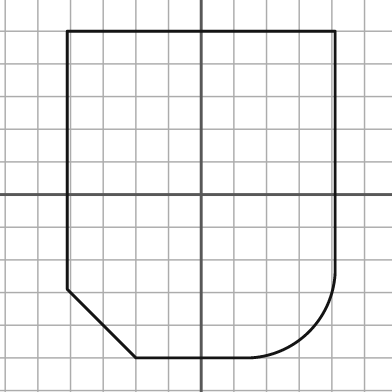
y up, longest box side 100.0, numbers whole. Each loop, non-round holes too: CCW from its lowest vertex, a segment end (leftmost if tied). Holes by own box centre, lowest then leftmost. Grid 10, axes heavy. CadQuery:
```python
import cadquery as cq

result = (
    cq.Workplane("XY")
    .moveTo(-20.0, -50.0)
    .lineTo(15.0, -50.0)
    .threePointArc((33.0, -42.0), (41.0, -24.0))
    .lineTo(41.0, 50.0)
    .lineTo(-41.0, 50.0)
    .lineTo(-41.0, -29.0)
    .close()
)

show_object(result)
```